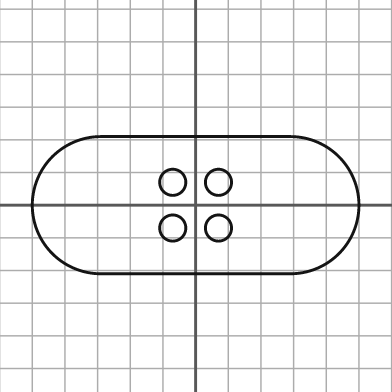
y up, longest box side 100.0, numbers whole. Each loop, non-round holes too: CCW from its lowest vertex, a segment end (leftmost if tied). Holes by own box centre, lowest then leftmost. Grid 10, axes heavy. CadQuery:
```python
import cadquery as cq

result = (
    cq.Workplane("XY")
    .moveTo(-29.0, -21.0)
    .lineTo(29.0, -21.0)
    .threePointArc((50.0, 0.0), (29.0, 21.0))
    .lineTo(-29.0, 21.0)
    .threePointArc((-50.0, 0.0), (-29.0, -21.0))
    .close()
    .moveTo(-7.0, -7.0)
    .circle(4.0)
    .moveTo(7.0, -7.0)
    .circle(4.0)
    .moveTo(-7.0, 7.0)
    .circle(4.0)
    .moveTo(7.0, 7.0)
    .circle(4.0)
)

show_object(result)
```